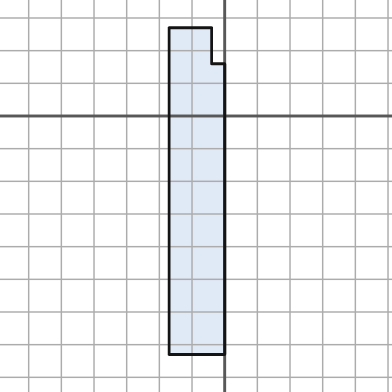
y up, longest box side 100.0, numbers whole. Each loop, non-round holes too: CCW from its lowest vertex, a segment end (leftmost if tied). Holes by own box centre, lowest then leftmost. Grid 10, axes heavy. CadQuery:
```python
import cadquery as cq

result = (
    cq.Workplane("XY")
    .moveTo(-17.0, -73.0)
    .lineTo(0.0, -73.0)
    .lineTo(0.0, 16.0)
    .lineTo(-4.0, 16.0)
    .lineTo(-4.0, 27.0)
    .lineTo(-17.0, 27.0)
    .close()
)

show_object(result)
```